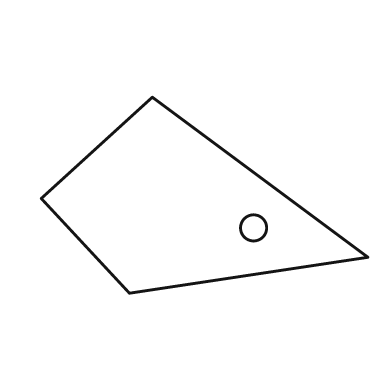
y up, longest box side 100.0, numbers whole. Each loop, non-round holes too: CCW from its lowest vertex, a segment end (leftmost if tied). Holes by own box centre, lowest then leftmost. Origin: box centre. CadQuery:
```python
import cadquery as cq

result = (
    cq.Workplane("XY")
    .moveTo(-23.0, -30.0)
    .lineTo(50.0, -19.0)
    .lineTo(-16.0, 30.0)
    .lineTo(-50.0, -1.0)
    .close()
    .moveTo(15.0, -10.0)
    .circle(4.0)
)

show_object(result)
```